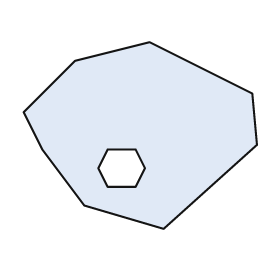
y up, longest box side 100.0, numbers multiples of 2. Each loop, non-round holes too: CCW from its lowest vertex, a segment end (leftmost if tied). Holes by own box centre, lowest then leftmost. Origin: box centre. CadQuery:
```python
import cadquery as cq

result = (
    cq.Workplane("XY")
    .moveTo(10.0, -40.0)
    .lineTo(50.0, -4.0)
    .lineTo(48.0, 18.0)
    .lineTo(4.0, 40.0)
    .lineTo(-28.0, 32.0)
    .lineTo(-50.0, 10.0)
    .lineTo(-42.0, -6.0)
    .lineTo(-24.0, -30.0)
    .close()
    .moveTo(-14.0, -22.0)
    .lineTo(-2.0, -22.0)
    .lineTo(2.0, -14.0)
    .lineTo(-2.0, -6.0)
    .lineTo(-14.0, -6.0)
    .lineTo(-18.0, -14.0)
    .close()
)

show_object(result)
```